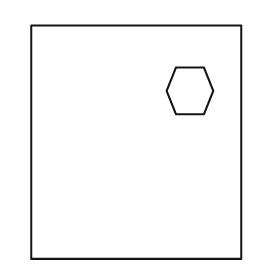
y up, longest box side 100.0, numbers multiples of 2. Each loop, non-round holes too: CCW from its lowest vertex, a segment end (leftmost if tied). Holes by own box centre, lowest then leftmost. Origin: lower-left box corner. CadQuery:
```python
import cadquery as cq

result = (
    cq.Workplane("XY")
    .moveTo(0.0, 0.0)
    .lineTo(90.0, 0.0)
    .lineTo(90.0, 100.0)
    .lineTo(0.0, 100.0)
    .close()
    .moveTo(62.0, 62.0)
    .lineTo(74.0, 62.0)
    .lineTo(78.0, 72.0)
    .lineTo(74.0, 82.0)
    .lineTo(62.0, 82.0)
    .lineTo(58.0, 72.0)
    .close()
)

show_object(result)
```